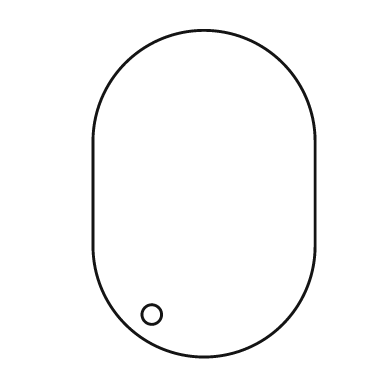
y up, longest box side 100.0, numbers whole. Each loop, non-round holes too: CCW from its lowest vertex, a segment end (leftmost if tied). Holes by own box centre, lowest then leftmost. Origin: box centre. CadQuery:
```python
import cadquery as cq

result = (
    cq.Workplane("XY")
    .moveTo(-34.0, -16.0)
    .threePointArc((0.0, -50.0), (34.0, -16.0))
    .lineTo(34.0, 16.0)
    .threePointArc((0.0, 50.0), (-34.0, 16.0))
    .close()
    .moveTo(-16.0, -37.0)
    .circle(3.0)
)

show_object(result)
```